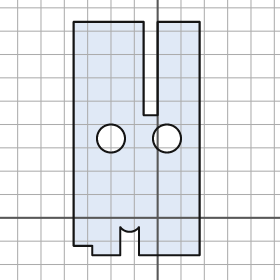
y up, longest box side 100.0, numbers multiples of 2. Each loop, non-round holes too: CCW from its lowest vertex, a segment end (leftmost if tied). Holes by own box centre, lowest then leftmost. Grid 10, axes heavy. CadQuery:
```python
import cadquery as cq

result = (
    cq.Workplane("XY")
    .moveTo(-28.0, -16.0)
    .lineTo(-16.0, -16.0)
    .lineTo(-16.0, -4.0)
    .threePointArc((-12.0, -6.0), (-8.0, -4.0))
    .lineTo(-8.0, -16.0)
    .lineTo(18.0, -16.0)
    .lineTo(18.0, 84.0)
    .lineTo(0.0, 84.0)
    .lineTo(0.0, 44.0)
    .lineTo(-6.0, 44.0)
    .lineTo(-6.0, 84.0)
    .lineTo(-36.0, 84.0)
    .lineTo(-36.0, -12.0)
    .lineTo(-28.0, -12.0)
    .close()
    .moveTo(-20.0, 34.0)
    .circle(6.0)
    .moveTo(4.0, 34.0)
    .circle(6.0)
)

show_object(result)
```